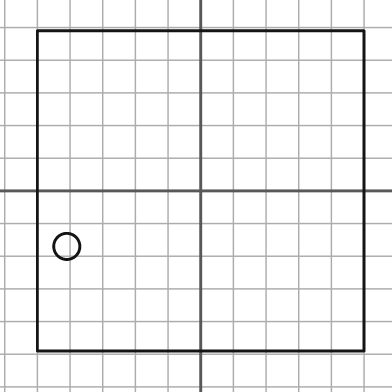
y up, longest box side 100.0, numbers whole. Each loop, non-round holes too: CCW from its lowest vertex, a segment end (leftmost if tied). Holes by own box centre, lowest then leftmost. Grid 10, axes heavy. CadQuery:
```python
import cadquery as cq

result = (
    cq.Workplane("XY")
    .moveTo(-50.0, -49.0)
    .lineTo(50.0, -49.0)
    .lineTo(50.0, 49.0)
    .lineTo(-50.0, 49.0)
    .close()
    .moveTo(-41.0, -17.0)
    .circle(4.0)
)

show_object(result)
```